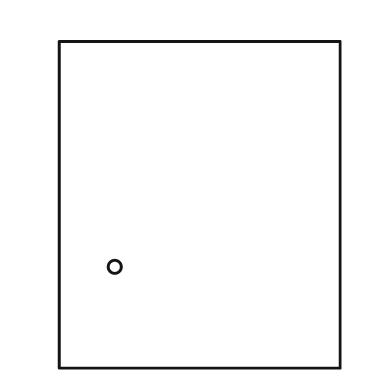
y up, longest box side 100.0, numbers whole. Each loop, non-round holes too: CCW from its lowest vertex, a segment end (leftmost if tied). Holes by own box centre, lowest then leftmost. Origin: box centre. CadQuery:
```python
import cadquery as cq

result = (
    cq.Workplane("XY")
    .moveTo(-43.0, -50.0)
    .lineTo(43.0, -50.0)
    .lineTo(43.0, 50.0)
    .lineTo(-43.0, 50.0)
    .close()
    .moveTo(-26.0, -19.0)
    .circle(2.0)
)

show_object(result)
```